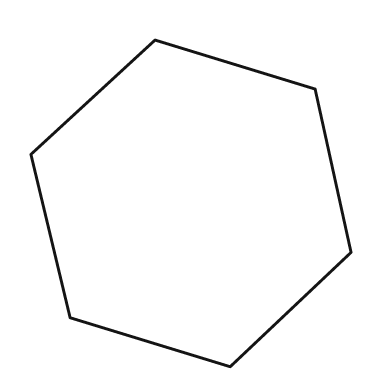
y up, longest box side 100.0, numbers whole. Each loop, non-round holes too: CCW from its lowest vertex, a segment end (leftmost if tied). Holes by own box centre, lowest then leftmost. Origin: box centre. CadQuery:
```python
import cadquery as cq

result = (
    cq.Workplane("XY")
    .moveTo(12.0, -50.0)
    .lineTo(49.0, -15.0)
    .lineTo(38.0, 35.0)
    .lineTo(-11.0, 50.0)
    .lineTo(-49.0, 15.0)
    .lineTo(-37.0, -35.0)
    .close()
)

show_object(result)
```